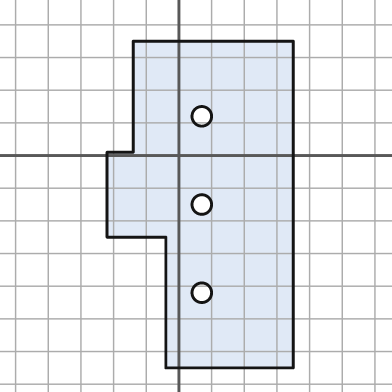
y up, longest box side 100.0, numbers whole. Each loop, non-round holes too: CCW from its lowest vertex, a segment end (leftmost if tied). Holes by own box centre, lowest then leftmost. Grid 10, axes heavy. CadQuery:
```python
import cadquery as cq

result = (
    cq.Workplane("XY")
    .moveTo(-4.0, -65.0)
    .lineTo(35.0, -65.0)
    .lineTo(35.0, 35.0)
    .lineTo(-14.0, 35.0)
    .lineTo(-14.0, 1.0)
    .lineTo(-22.0, 1.0)
    .lineTo(-22.0, -25.0)
    .lineTo(-4.0, -25.0)
    .close()
    .moveTo(7.0, -42.0)
    .circle(3.0)
    .moveTo(7.0, -15.0)
    .circle(3.0)
    .moveTo(7.0, 12.0)
    .circle(3.0)
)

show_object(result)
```